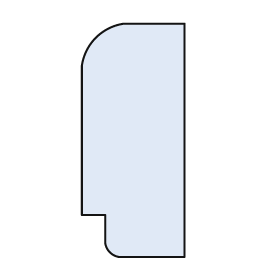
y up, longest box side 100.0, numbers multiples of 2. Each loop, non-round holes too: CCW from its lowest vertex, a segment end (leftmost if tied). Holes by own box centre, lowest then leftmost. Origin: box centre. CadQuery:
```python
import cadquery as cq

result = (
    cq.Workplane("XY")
    .moveTo(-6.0, -50.0)
    .lineTo(22.0, -50.0)
    .lineTo(22.0, 50.0)
    .lineTo(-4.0, 50.0)
    .threePointArc((-16.0, 44.0), (-22.0, 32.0))
    .lineTo(-22.0, -32.0)
    .lineTo(-12.0, -32.0)
    .lineTo(-12.0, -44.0)
    .threePointArc((-10.0, -48.0), (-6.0, -50.0))
    .close()
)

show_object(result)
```